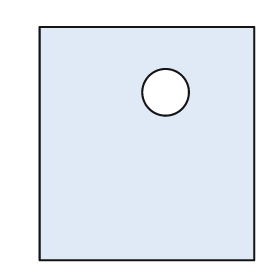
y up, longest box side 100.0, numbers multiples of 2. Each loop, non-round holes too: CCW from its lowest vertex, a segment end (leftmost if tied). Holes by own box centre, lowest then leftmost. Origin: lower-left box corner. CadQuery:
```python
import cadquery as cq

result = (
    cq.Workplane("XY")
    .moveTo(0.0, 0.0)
    .lineTo(92.0, 0.0)
    .lineTo(92.0, 100.0)
    .lineTo(0.0, 100.0)
    .close()
    .moveTo(54.0, 72.0)
    .circle(10.0)
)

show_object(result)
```